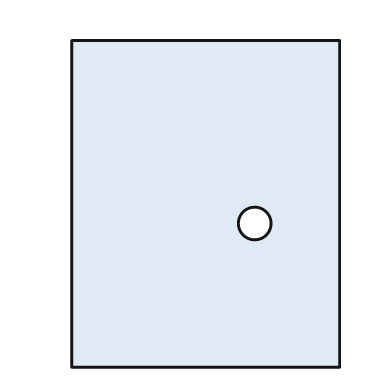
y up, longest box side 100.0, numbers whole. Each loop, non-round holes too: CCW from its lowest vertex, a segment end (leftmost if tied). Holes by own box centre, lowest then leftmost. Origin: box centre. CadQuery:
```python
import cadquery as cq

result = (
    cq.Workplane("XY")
    .moveTo(-41.0, -50.0)
    .lineTo(41.0, -50.0)
    .lineTo(41.0, 50.0)
    .lineTo(-41.0, 50.0)
    .close()
    .moveTo(15.0, -6.0)
    .circle(5.0)
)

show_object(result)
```